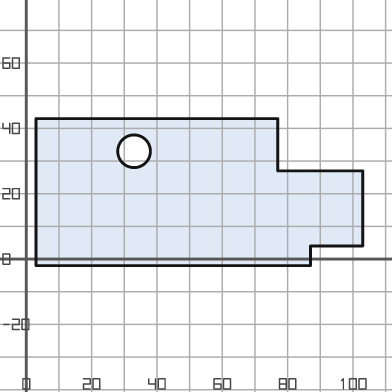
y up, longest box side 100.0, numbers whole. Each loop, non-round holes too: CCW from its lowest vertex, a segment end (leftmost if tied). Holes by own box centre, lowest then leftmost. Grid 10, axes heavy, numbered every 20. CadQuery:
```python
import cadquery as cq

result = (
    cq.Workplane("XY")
    .moveTo(3.0, -2.0)
    .lineTo(87.0, -2.0)
    .lineTo(87.0, 4.0)
    .lineTo(103.0, 4.0)
    .lineTo(103.0, 27.0)
    .lineTo(77.0, 27.0)
    .lineTo(77.0, 43.0)
    .lineTo(3.0, 43.0)
    .close()
    .moveTo(33.0, 33.0)
    .circle(5.0)
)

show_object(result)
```